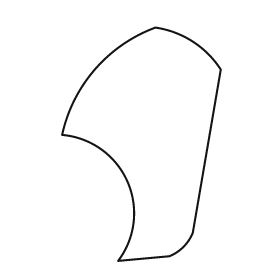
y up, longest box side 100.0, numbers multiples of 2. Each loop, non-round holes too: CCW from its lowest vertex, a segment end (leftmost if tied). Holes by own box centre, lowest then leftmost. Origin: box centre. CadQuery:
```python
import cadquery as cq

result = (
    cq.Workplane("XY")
    .moveTo(-10.0, -50.0)
    .lineTo(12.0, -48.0)
    .threePointArc((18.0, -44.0), (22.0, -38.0))
    .lineTo(34.0, 32.0)
    .threePointArc((22.0, 44.0), (6.0, 50.0))
    .threePointArc((-20.0, 32.0), (-34.0, 4.0))
    .threePointArc((-6.0, -16.0), (-10.0, -50.0))
    .close()
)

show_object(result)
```